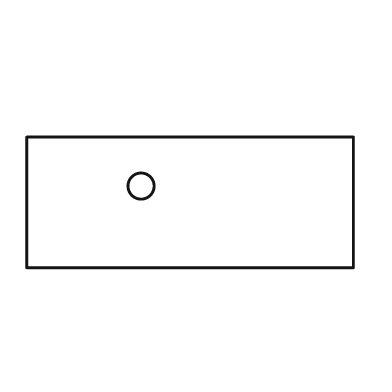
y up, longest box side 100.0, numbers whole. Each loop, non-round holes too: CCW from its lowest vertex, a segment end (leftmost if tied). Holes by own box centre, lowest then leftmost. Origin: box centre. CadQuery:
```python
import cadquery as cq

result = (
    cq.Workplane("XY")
    .moveTo(-50.0, -20.0)
    .lineTo(50.0, -20.0)
    .lineTo(50.0, 20.0)
    .lineTo(-50.0, 20.0)
    .close()
    .moveTo(-15.0, 5.0)
    .circle(4.0)
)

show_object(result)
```